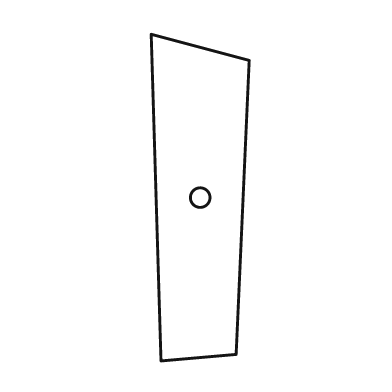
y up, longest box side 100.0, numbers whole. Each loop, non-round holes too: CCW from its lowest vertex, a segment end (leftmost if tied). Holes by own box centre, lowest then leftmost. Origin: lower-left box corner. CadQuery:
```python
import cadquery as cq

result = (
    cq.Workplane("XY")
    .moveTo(3.0, 0.0)
    .lineTo(26.0, 2.0)
    .lineTo(30.0, 92.0)
    .lineTo(0.0, 100.0)
    .close()
    .moveTo(15.0, 50.0)
    .circle(3.0)
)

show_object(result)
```